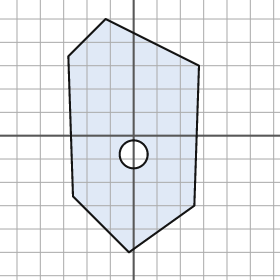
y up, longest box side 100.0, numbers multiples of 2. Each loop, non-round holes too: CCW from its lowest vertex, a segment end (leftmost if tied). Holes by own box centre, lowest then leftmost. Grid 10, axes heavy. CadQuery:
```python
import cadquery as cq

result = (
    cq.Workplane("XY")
    .moveTo(-2.0, -50.0)
    .lineTo(26.0, -30.0)
    .lineTo(28.0, 30.0)
    .lineTo(-12.0, 50.0)
    .lineTo(-28.0, 34.0)
    .lineTo(-26.0, -26.0)
    .close()
    .moveTo(0.0, -8.0)
    .circle(6.0)
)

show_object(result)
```